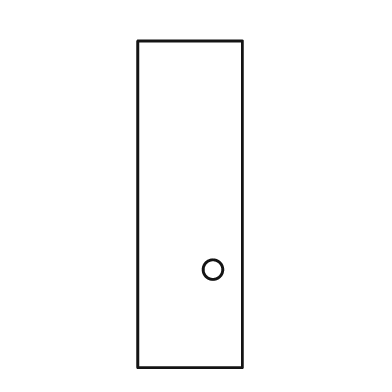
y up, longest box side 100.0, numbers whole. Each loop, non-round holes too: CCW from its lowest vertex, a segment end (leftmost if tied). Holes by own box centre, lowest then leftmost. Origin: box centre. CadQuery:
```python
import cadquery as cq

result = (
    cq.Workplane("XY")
    .moveTo(-16.0, -50.0)
    .lineTo(16.0, -50.0)
    .lineTo(16.0, 50.0)
    .lineTo(-16.0, 50.0)
    .close()
    .moveTo(7.0, -20.0)
    .circle(3.0)
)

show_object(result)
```